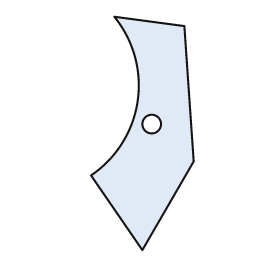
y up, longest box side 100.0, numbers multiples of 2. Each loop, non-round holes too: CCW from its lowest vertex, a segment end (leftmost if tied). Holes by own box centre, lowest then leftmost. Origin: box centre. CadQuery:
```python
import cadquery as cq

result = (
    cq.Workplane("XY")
    .moveTo(0.0, -50.0)
    .lineTo(22.0, -12.0)
    .lineTo(18.0, 46.0)
    .lineTo(-12.0, 50.0)
    .threePointArc((-2.0, 14.0), (-22.0, -18.0))
    .close()
    .moveTo(4.0, 4.0)
    .circle(4.0)
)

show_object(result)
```